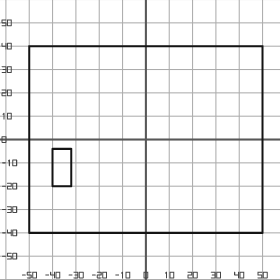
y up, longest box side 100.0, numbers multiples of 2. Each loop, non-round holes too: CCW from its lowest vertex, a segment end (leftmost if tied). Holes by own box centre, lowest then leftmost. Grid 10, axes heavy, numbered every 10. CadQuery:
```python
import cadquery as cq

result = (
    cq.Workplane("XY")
    .moveTo(-50.0, -40.0)
    .lineTo(50.0, -40.0)
    .lineTo(50.0, 40.0)
    .lineTo(-50.0, 40.0)
    .close()
    .moveTo(-40.0, -20.0)
    .lineTo(-32.0, -20.0)
    .lineTo(-32.0, -4.0)
    .lineTo(-40.0, -4.0)
    .close()
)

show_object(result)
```